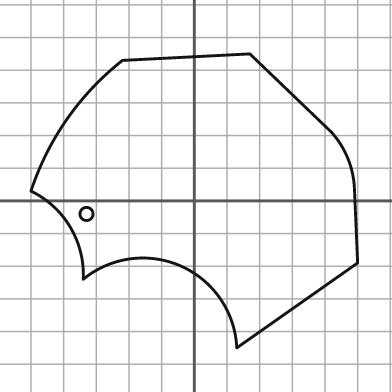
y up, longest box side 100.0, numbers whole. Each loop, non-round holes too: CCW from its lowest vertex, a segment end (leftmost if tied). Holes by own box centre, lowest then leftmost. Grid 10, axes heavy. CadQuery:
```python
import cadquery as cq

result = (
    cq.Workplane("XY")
    .moveTo(13.0, -45.0)
    .lineTo(50.0, -19.0)
    .lineTo(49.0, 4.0)
    .threePointArc((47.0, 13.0), (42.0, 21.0))
    .lineTo(17.0, 45.0)
    .lineTo(-22.0, 43.0)
    .threePointArc((-39.0, 25.0), (-50.0, 3.0))
    .threePointArc((-38.0, -8.0), (-34.0, -24.0))
    .threePointArc((-4.0, -20.0), (13.0, -45.0))
    .close()
    .moveTo(-33.0, -4.0)
    .circle(2.0)
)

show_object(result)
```